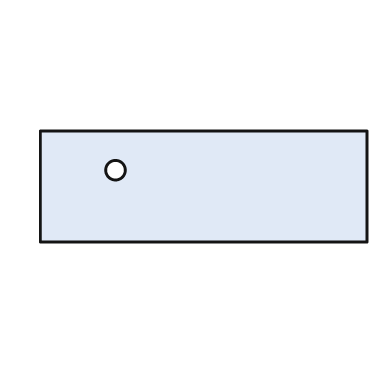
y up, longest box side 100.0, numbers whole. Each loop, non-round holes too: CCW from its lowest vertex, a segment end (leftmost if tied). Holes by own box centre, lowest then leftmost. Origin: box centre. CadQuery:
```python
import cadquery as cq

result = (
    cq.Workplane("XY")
    .moveTo(-50.0, -17.0)
    .lineTo(50.0, -17.0)
    .lineTo(50.0, 17.0)
    .lineTo(-50.0, 17.0)
    .close()
    .moveTo(-27.0, 5.0)
    .circle(3.0)
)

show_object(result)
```